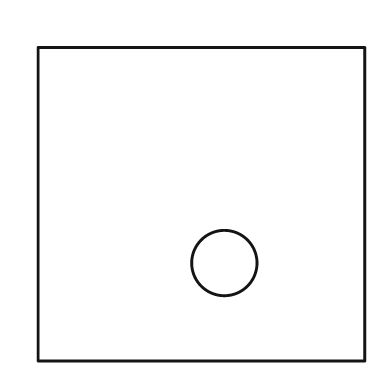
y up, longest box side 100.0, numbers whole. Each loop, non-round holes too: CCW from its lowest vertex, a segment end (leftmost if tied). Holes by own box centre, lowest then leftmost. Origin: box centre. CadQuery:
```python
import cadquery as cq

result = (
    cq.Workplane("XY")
    .moveTo(-50.0, -48.0)
    .lineTo(50.0, -48.0)
    .lineTo(50.0, 48.0)
    .lineTo(-50.0, 48.0)
    .close()
    .moveTo(7.0, -18.0)
    .circle(10.0)
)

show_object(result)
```